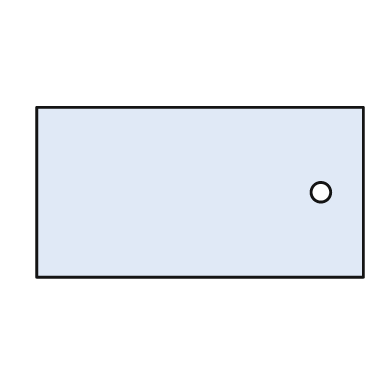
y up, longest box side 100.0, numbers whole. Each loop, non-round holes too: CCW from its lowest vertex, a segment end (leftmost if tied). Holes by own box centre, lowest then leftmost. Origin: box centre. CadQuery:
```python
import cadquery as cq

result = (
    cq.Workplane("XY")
    .moveTo(-50.0, -26.0)
    .lineTo(50.0, -26.0)
    .lineTo(50.0, 26.0)
    .lineTo(-50.0, 26.0)
    .close()
    .moveTo(37.0, 0.0)
    .circle(3.0)
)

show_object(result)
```